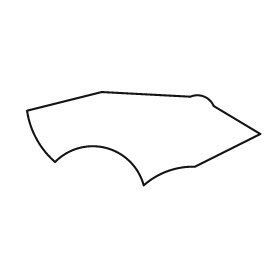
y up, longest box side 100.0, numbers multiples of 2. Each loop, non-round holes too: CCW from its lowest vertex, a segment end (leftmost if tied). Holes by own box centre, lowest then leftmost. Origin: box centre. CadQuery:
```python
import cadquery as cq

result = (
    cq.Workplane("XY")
    .moveTo(0.0, -20.0)
    .threePointArc((10.0, -14.0), (22.0, -12.0))
    .lineTo(50.0, 2.0)
    .lineTo(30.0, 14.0)
    .threePointArc((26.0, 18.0), (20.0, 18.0))
    .lineTo(-18.0, 20.0)
    .lineTo(-50.0, 12.0)
    .threePointArc((-46.0, 0.0), (-38.0, -10.0))
    .threePointArc((-16.0, -4.0), (0.0, -20.0))
    .close()
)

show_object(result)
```